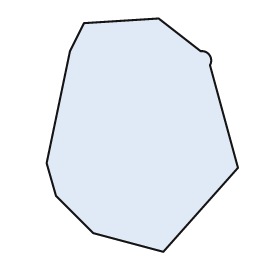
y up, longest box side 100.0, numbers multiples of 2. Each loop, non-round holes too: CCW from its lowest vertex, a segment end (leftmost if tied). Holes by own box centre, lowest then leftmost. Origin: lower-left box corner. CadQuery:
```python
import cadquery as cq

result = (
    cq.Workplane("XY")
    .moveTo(50.0, 0.0)
    .lineTo(82.0, 36.0)
    .lineTo(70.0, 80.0)
    .threePointArc((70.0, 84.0), (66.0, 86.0))
    .lineTo(48.0, 100.0)
    .lineTo(16.0, 98.0)
    .lineTo(10.0, 86.0)
    .lineTo(0.0, 38.0)
    .lineTo(4.0, 24.0)
    .lineTo(20.0, 8.0)
    .close()
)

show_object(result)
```